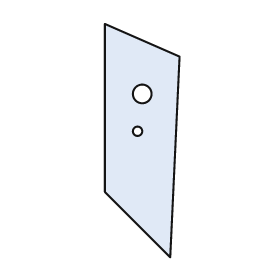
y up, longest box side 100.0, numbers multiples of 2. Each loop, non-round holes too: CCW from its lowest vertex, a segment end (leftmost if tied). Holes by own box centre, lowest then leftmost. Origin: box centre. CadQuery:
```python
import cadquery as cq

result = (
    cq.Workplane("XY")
    .moveTo(12.0, -50.0)
    .lineTo(16.0, 36.0)
    .lineTo(-16.0, 50.0)
    .lineTo(-16.0, -22.0)
    .close()
    .moveTo(-2.0, 4.0)
    .circle(2.0)
    .moveTo(0.0, 20.0)
    .circle(4.0)
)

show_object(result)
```